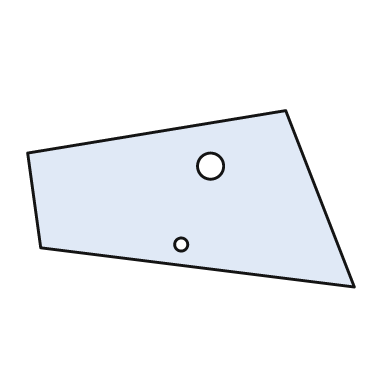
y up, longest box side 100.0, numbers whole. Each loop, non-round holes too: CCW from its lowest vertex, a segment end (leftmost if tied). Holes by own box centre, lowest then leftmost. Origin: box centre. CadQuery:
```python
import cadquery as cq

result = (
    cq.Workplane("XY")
    .moveTo(50.0, -27.0)
    .lineTo(29.0, 27.0)
    .lineTo(-50.0, 14.0)
    .lineTo(-46.0, -15.0)
    .close()
    .moveTo(-3.0, -14.0)
    .circle(2.0)
    .moveTo(6.0, 10.0)
    .circle(4.0)
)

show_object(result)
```